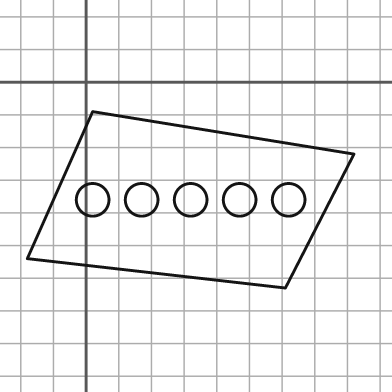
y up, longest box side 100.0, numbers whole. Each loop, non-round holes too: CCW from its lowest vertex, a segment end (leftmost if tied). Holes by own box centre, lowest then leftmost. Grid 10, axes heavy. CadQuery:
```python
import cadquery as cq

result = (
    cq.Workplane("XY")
    .moveTo(61.0, -63.0)
    .lineTo(82.0, -22.0)
    .lineTo(2.0, -9.0)
    .lineTo(-18.0, -54.0)
    .close()
    .moveTo(2.0, -36.0)
    .circle(5.0)
    .moveTo(17.0, -36.0)
    .circle(5.0)
    .moveTo(32.0, -36.0)
    .circle(5.0)
    .moveTo(47.0, -36.0)
    .circle(5.0)
    .moveTo(62.0, -36.0)
    .circle(5.0)
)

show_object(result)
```